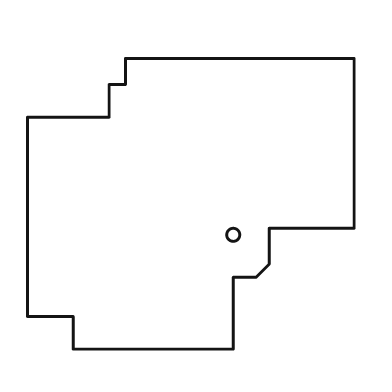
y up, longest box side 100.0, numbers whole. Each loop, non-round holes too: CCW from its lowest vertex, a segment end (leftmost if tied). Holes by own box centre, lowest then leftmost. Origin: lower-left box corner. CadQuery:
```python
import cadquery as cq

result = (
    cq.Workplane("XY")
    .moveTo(14.0, 0.0)
    .lineTo(63.0, 0.0)
    .lineTo(63.0, 22.0)
    .lineTo(70.0, 22.0)
    .lineTo(74.0, 26.0)
    .lineTo(74.0, 37.0)
    .lineTo(100.0, 37.0)
    .lineTo(100.0, 89.0)
    .lineTo(30.0, 89.0)
    .lineTo(30.0, 81.0)
    .lineTo(25.0, 81.0)
    .lineTo(25.0, 71.0)
    .lineTo(0.0, 71.0)
    .lineTo(0.0, 10.0)
    .lineTo(14.0, 10.0)
    .close()
    .moveTo(63.0, 35.0)
    .circle(2.0)
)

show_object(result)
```